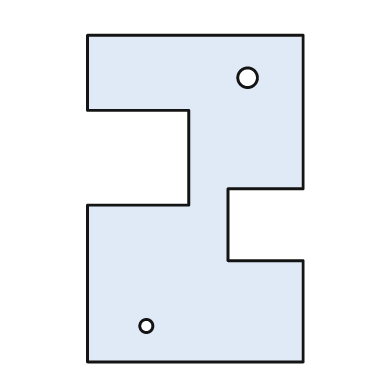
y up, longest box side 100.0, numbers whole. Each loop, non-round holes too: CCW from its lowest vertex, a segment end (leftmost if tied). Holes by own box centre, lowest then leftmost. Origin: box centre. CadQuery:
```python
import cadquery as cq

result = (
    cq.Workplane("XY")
    .moveTo(-33.0, -50.0)
    .lineTo(33.0, -50.0)
    .lineTo(33.0, -19.0)
    .lineTo(10.0, -19.0)
    .lineTo(10.0, 3.0)
    .lineTo(33.0, 3.0)
    .lineTo(33.0, 50.0)
    .lineTo(-33.0, 50.0)
    .lineTo(-33.0, 27.0)
    .lineTo(-2.0, 27.0)
    .lineTo(-2.0, -2.0)
    .lineTo(-33.0, -2.0)
    .close()
    .moveTo(-15.0, -39.0)
    .circle(2.0)
    .moveTo(16.0, 37.0)
    .circle(3.0)
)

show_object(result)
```